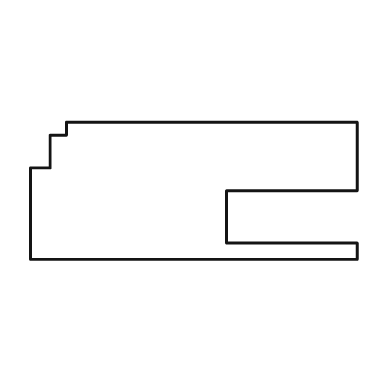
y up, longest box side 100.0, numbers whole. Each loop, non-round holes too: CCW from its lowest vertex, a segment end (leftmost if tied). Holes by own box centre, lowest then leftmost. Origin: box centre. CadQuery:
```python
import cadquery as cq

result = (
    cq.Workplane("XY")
    .moveTo(-50.0, -21.0)
    .lineTo(50.0, -21.0)
    .lineTo(50.0, -16.0)
    .lineTo(10.0, -16.0)
    .lineTo(10.0, 0.0)
    .lineTo(50.0, 0.0)
    .lineTo(50.0, 21.0)
    .lineTo(-39.0, 21.0)
    .lineTo(-39.0, 17.0)
    .lineTo(-44.0, 17.0)
    .lineTo(-44.0, 7.0)
    .lineTo(-50.0, 7.0)
    .close()
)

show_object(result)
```